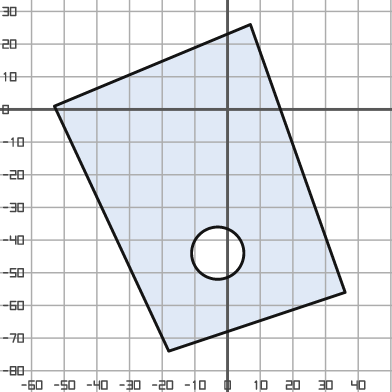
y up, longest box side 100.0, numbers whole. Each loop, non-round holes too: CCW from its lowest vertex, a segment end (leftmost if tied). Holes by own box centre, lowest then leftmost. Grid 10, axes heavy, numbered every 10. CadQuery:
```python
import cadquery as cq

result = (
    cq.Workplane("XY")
    .moveTo(-18.0, -74.0)
    .lineTo(36.0, -56.0)
    .lineTo(7.0, 26.0)
    .lineTo(-53.0, 1.0)
    .close()
    .moveTo(-3.0, -44.0)
    .circle(8.0)
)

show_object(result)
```